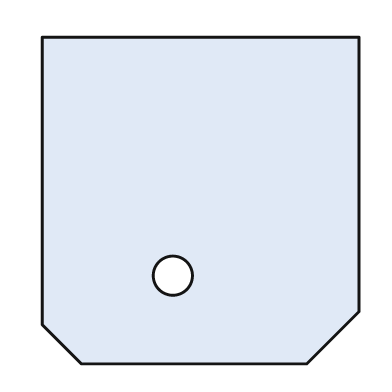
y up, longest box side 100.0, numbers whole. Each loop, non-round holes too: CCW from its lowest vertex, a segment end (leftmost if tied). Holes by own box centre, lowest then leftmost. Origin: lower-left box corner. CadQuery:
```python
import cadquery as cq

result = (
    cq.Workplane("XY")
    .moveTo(12.0, 0.0)
    .lineTo(81.0, 0.0)
    .lineTo(97.0, 16.0)
    .lineTo(97.0, 100.0)
    .lineTo(0.0, 100.0)
    .lineTo(0.0, 12.0)
    .close()
    .moveTo(40.0, 27.0)
    .circle(6.0)
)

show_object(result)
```